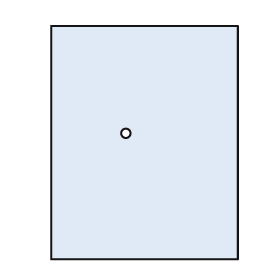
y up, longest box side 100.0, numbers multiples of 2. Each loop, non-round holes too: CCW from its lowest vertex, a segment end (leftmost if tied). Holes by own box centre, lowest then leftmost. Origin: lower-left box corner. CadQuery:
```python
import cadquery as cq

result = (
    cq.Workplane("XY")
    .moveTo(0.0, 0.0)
    .lineTo(80.0, 0.0)
    .lineTo(80.0, 100.0)
    .lineTo(0.0, 100.0)
    .close()
    .moveTo(32.0, 54.0)
    .circle(2.0)
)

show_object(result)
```